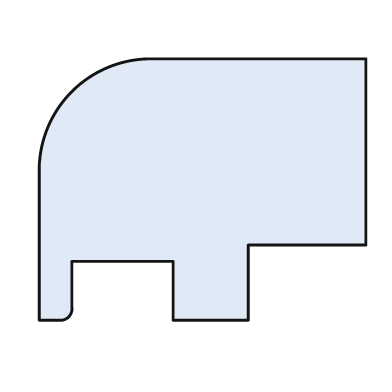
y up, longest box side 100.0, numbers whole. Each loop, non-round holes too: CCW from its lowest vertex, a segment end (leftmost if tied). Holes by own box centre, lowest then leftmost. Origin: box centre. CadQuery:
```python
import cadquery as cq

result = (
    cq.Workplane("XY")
    .moveTo(-50.0, -40.0)
    .lineTo(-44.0, -40.0)
    .threePointArc((-41.0, -39.0), (-40.0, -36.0))
    .lineTo(-40.0, -22.0)
    .lineTo(-9.0, -22.0)
    .lineTo(-9.0, -40.0)
    .lineTo(14.0, -40.0)
    .lineTo(14.0, -17.0)
    .lineTo(50.0, -17.0)
    .lineTo(50.0, 40.0)
    .lineTo(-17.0, 40.0)
    .threePointArc((-40.0, 30.0), (-50.0, 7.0))
    .close()
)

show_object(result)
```